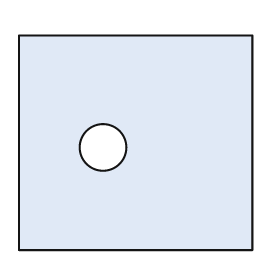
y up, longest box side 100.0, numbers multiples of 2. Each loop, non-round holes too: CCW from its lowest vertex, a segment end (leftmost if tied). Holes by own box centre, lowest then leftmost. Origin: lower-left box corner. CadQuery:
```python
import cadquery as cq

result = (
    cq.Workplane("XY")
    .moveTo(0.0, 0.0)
    .lineTo(100.0, 0.0)
    .lineTo(100.0, 92.0)
    .lineTo(0.0, 92.0)
    .close()
    .moveTo(36.0, 44.0)
    .circle(10.0)
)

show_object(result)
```